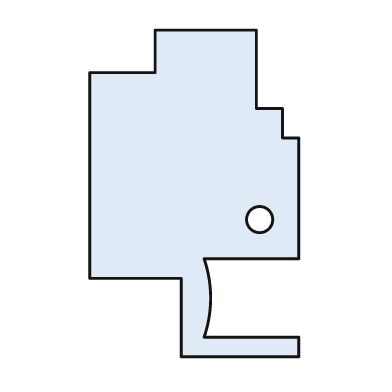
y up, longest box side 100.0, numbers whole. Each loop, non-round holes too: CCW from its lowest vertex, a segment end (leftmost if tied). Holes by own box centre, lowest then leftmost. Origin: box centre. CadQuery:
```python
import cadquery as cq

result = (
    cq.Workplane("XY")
    .moveTo(-4.0, -50.0)
    .lineTo(32.0, -50.0)
    .lineTo(32.0, -44.0)
    .lineTo(3.0, -44.0)
    .threePointArc((5.0, -32.0), (3.0, -20.0))
    .lineTo(32.0, -20.0)
    .lineTo(32.0, 17.0)
    .lineTo(27.0, 17.0)
    .lineTo(27.0, 26.0)
    .lineTo(19.0, 26.0)
    .lineTo(19.0, 50.0)
    .lineTo(-12.0, 50.0)
    .lineTo(-12.0, 37.0)
    .lineTo(-32.0, 37.0)
    .lineTo(-32.0, -26.0)
    .lineTo(-4.0, -26.0)
    .close()
    .moveTo(20.0, -8.0)
    .circle(4.0)
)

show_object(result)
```